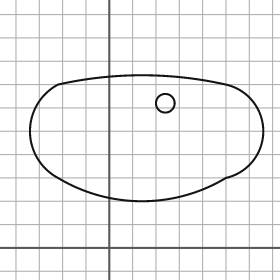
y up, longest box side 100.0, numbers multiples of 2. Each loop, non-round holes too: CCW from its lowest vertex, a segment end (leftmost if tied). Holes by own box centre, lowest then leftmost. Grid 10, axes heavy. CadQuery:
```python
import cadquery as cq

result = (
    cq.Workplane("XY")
    .moveTo(-22.0, 30.0)
    .threePointArc((14.0, 20.0), (50.0, 30.0))
    .threePointArc((66.0, 50.0), (50.0, 70.0))
    .threePointArc((14.0, 74.0), (-22.0, 70.0))
    .threePointArc((-34.0, 50.0), (-22.0, 30.0))
    .close()
    .moveTo(24.0, 62.0)
    .circle(4.0)
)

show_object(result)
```